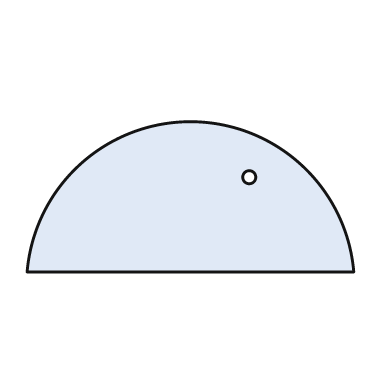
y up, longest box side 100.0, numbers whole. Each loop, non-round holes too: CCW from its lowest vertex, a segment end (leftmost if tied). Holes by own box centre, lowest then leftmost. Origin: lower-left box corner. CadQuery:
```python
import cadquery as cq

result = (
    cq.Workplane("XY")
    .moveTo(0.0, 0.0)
    .lineTo(100.0, 0.0)
    .threePointArc((50.0, 46.0), (0.0, 0.0))
    .close()
    .moveTo(68.0, 29.0)
    .circle(2.0)
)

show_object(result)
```